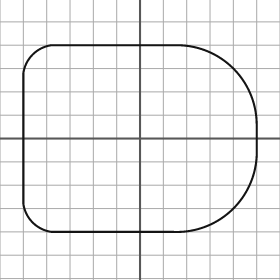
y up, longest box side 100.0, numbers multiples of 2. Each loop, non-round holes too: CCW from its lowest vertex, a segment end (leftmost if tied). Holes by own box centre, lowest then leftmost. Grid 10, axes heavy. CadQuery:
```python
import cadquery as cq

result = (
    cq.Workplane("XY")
    .moveTo(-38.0, -40.0)
    .lineTo(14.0, -40.0)
    .threePointArc((40.0, -30.0), (50.0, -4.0))
    .lineTo(50.0, 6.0)
    .threePointArc((40.0, 30.0), (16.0, 40.0))
    .lineTo(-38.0, 40.0)
    .threePointArc((-46.0, 36.0), (-50.0, 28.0))
    .lineTo(-50.0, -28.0)
    .threePointArc((-46.0, -36.0), (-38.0, -40.0))
    .close()
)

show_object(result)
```